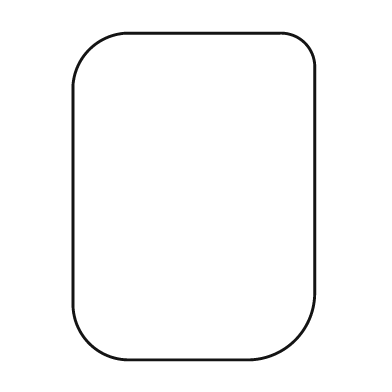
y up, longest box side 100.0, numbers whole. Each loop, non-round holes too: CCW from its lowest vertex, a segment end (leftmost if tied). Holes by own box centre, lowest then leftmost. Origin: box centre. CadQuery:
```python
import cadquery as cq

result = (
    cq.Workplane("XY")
    .moveTo(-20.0, -50.0)
    .lineTo(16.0, -50.0)
    .threePointArc((31.0, -44.0), (37.0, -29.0))
    .lineTo(37.0, 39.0)
    .threePointArc((34.0, 47.0), (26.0, 50.0))
    .lineTo(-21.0, 50.0)
    .threePointArc((-32.0, 45.0), (-37.0, 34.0))
    .lineTo(-37.0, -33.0)
    .threePointArc((-32.0, -45.0), (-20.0, -50.0))
    .close()
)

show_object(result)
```